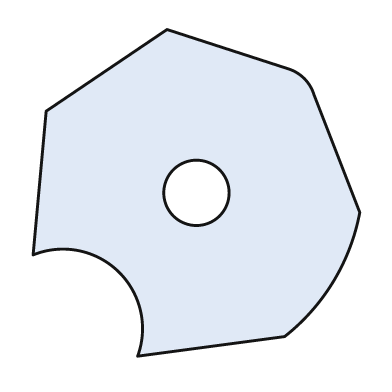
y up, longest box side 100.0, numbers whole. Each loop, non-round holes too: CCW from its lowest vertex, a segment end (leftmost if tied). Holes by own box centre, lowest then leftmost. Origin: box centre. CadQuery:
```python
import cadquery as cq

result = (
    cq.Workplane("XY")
    .moveTo(-18.0, -50.0)
    .lineTo(27.0, -44.0)
    .threePointArc((42.0, -27.0), (50.0, -6.0))
    .lineTo(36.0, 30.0)
    .threePointArc((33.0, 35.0), (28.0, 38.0))
    .lineTo(-9.0, 50.0)
    .lineTo(-46.0, 25.0)
    .lineTo(-50.0, -19.0)
    .threePointArc((-24.0, -24.0), (-18.0, -50.0))
    .close()
    .moveTo(0.0, 0.0)
    .circle(10.0)
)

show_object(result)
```